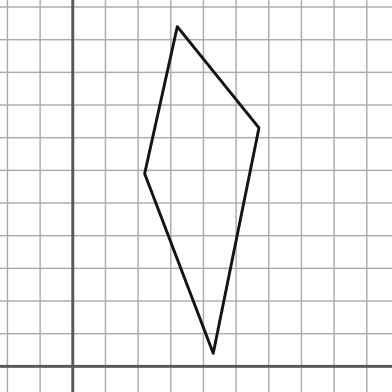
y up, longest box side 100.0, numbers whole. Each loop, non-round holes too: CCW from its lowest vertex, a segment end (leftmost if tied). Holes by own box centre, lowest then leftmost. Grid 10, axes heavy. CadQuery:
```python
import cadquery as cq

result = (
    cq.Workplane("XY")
    .moveTo(43.0, 4.0)
    .lineTo(57.0, 73.0)
    .lineTo(32.0, 104.0)
    .lineTo(22.0, 59.0)
    .close()
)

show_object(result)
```